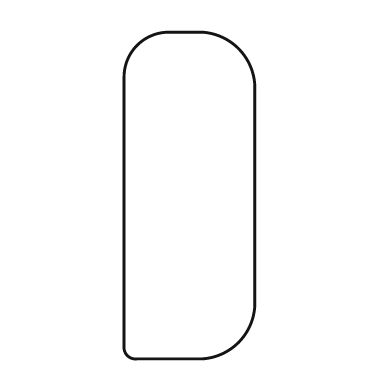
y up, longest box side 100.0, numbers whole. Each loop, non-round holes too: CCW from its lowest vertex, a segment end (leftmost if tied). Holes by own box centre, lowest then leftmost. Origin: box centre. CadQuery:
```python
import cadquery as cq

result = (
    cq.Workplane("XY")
    .moveTo(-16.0, -50.0)
    .lineTo(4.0, -50.0)
    .threePointArc((15.0, -45.0), (20.0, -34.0))
    .lineTo(20.0, 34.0)
    .threePointArc((15.0, 45.0), (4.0, 50.0))
    .lineTo(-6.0, 50.0)
    .threePointArc((-16.0, 46.0), (-20.0, 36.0))
    .lineTo(-20.0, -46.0)
    .threePointArc((-19.0, -49.0), (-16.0, -50.0))
    .close()
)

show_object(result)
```